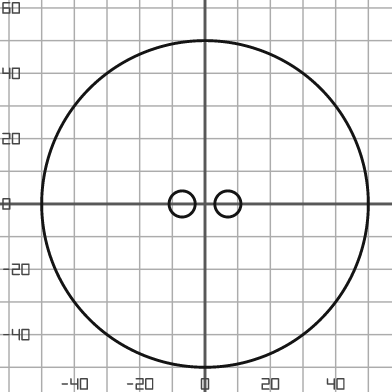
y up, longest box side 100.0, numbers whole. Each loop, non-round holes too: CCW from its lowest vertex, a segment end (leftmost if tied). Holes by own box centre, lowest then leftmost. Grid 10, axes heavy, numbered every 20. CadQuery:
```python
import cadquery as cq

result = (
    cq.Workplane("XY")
    .moveTo(0.0, 0.0)
    .circle(50.0)
    .moveTo(-7.0, 0.0)
    .circle(4.0)
    .moveTo(7.0, 0.0)
    .circle(4.0)
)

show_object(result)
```